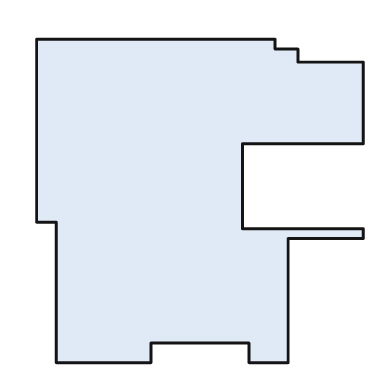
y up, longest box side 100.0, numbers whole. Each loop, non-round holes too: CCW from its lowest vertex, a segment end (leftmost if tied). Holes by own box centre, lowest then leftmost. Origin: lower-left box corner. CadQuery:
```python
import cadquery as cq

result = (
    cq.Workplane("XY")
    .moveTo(6.0, 0.0)
    .lineTo(35.0, 0.0)
    .lineTo(35.0, 6.0)
    .lineTo(65.0, 6.0)
    .lineTo(65.0, 0.0)
    .lineTo(77.0, 0.0)
    .lineTo(77.0, 38.0)
    .lineTo(100.0, 38.0)
    .lineTo(100.0, 41.0)
    .lineTo(63.0, 41.0)
    .lineTo(63.0, 67.0)
    .lineTo(100.0, 67.0)
    .lineTo(100.0, 92.0)
    .lineTo(80.0, 92.0)
    .lineTo(80.0, 96.0)
    .lineTo(73.0, 96.0)
    .lineTo(73.0, 99.0)
    .lineTo(0.0, 99.0)
    .lineTo(0.0, 43.0)
    .lineTo(6.0, 43.0)
    .close()
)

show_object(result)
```